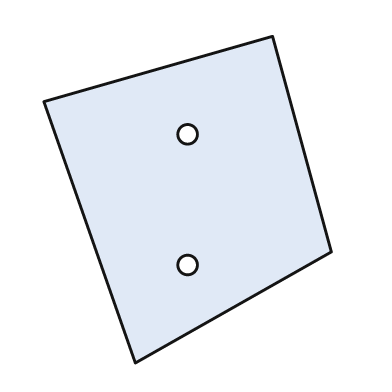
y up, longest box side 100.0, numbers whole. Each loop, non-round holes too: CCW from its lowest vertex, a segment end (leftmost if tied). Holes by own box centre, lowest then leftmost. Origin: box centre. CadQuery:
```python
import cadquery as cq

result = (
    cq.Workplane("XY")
    .moveTo(-16.0, -50.0)
    .lineTo(44.0, -16.0)
    .lineTo(26.0, 50.0)
    .lineTo(-44.0, 30.0)
    .close()
    .moveTo(0.0, -20.0)
    .circle(3.0)
    .moveTo(0.0, 20.0)
    .circle(3.0)
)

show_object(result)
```